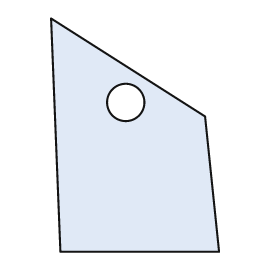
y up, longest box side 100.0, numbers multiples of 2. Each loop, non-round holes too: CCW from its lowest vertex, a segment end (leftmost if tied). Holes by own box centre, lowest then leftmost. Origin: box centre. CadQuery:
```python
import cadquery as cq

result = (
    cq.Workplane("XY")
    .moveTo(-32.0, -50.0)
    .lineTo(36.0, -50.0)
    .lineTo(30.0, 8.0)
    .lineTo(-36.0, 50.0)
    .close()
    .moveTo(-4.0, 14.0)
    .circle(8.0)
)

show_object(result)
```